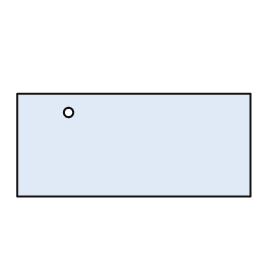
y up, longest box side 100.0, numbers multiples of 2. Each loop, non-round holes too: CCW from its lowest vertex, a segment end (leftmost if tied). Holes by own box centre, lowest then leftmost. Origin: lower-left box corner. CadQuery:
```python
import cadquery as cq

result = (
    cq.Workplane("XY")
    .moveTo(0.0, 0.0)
    .lineTo(100.0, 0.0)
    .lineTo(100.0, 44.0)
    .lineTo(0.0, 44.0)
    .close()
    .moveTo(22.0, 36.0)
    .circle(2.0)
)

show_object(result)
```